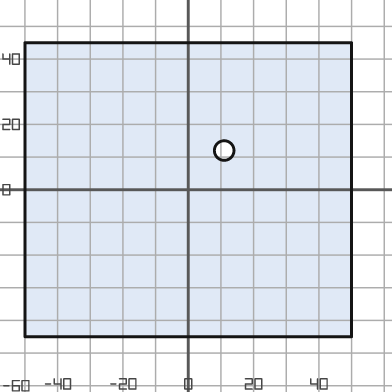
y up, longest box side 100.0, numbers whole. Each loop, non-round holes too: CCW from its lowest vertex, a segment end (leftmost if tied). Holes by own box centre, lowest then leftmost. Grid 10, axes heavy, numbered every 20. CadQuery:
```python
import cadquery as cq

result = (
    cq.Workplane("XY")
    .moveTo(-50.0, -45.0)
    .lineTo(50.0, -45.0)
    .lineTo(50.0, 45.0)
    .lineTo(-50.0, 45.0)
    .close()
    .moveTo(11.0, 12.0)
    .circle(3.0)
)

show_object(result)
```